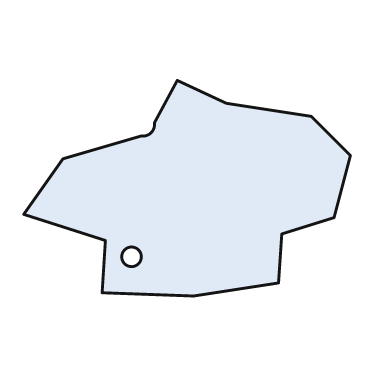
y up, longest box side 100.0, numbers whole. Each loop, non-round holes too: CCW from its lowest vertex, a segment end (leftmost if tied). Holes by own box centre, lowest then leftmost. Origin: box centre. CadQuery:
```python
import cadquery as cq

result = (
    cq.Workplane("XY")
    .moveTo(2.0, -33.0)
    .lineTo(28.0, -29.0)
    .lineTo(29.0, -14.0)
    .lineTo(45.0, -9.0)
    .lineTo(50.0, 10.0)
    .lineTo(38.0, 22.0)
    .lineTo(12.0, 26.0)
    .lineTo(-3.0, 33.0)
    .lineTo(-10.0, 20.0)
    .threePointArc((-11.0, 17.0), (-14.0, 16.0))
    .lineTo(-38.0, 9.0)
    .lineTo(-50.0, -8.0)
    .lineTo(-25.0, -16.0)
    .lineTo(-26.0, -32.0)
    .close()
    .moveTo(-17.0, -21.0)
    .circle(3.0)
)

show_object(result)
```